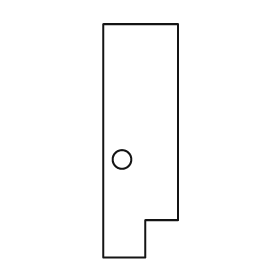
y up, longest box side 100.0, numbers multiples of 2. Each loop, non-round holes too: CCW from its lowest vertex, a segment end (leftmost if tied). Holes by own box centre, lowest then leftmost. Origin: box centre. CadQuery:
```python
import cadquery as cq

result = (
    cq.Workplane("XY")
    .moveTo(-16.0, -50.0)
    .lineTo(2.0, -50.0)
    .lineTo(2.0, -34.0)
    .lineTo(16.0, -34.0)
    .lineTo(16.0, 50.0)
    .lineTo(-16.0, 50.0)
    .close()
    .moveTo(-8.0, -8.0)
    .circle(4.0)
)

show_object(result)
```